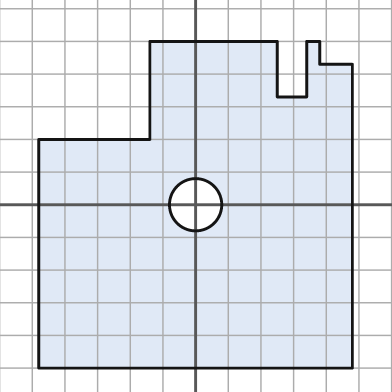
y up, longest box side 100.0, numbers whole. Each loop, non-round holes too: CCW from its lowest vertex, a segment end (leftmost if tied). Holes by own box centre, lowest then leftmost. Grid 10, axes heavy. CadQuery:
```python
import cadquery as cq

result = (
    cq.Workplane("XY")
    .moveTo(-48.0, -50.0)
    .lineTo(48.0, -50.0)
    .lineTo(48.0, 43.0)
    .lineTo(38.0, 43.0)
    .lineTo(38.0, 50.0)
    .lineTo(34.0, 50.0)
    .lineTo(34.0, 33.0)
    .lineTo(25.0, 33.0)
    .lineTo(25.0, 50.0)
    .lineTo(-14.0, 50.0)
    .lineTo(-14.0, 20.0)
    .lineTo(-48.0, 20.0)
    .close()
    .moveTo(0.0, 0.0)
    .circle(8.0)
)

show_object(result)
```